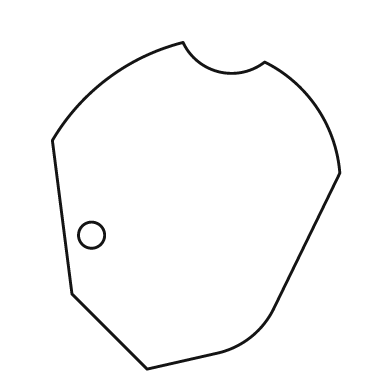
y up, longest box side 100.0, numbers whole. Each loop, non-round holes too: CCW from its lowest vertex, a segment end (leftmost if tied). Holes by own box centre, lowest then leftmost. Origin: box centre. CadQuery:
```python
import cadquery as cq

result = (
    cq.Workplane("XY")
    .moveTo(-15.0, -50.0)
    .lineTo(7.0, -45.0)
    .threePointArc((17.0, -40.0), (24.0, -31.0))
    .lineTo(44.0, 10.0)
    .threePointArc((37.0, 30.0), (21.0, 44.0))
    .threePointArc((7.0, 41.0), (-4.0, 50.0))
    .threePointArc((-27.0, 39.0), (-44.0, 20.0))
    .lineTo(-38.0, -27.0)
    .close()
    .moveTo(-32.0, -9.0)
    .circle(4.0)
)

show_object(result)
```